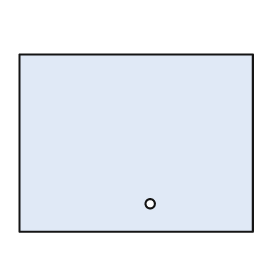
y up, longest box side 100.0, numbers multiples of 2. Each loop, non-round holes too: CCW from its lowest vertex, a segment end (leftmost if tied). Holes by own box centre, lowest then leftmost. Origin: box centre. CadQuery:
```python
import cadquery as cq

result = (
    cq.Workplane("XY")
    .moveTo(-50.0, -38.0)
    .lineTo(50.0, -38.0)
    .lineTo(50.0, 38.0)
    .lineTo(-50.0, 38.0)
    .close()
    .moveTo(6.0, -26.0)
    .circle(2.0)
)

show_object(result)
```